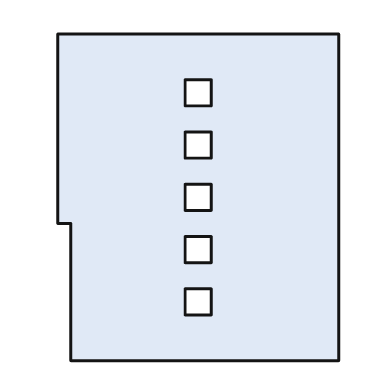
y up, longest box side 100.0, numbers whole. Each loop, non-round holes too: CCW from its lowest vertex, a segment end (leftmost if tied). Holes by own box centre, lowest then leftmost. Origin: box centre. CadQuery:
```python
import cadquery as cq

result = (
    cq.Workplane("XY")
    .moveTo(-39.0, -50.0)
    .lineTo(43.0, -50.0)
    .lineTo(43.0, 50.0)
    .lineTo(-43.0, 50.0)
    .lineTo(-43.0, -8.0)
    .lineTo(-39.0, -8.0)
    .close()
    .moveTo(-4.0, -36.0)
    .lineTo(4.0, -36.0)
    .lineTo(4.0, -28.0)
    .lineTo(-4.0, -28.0)
    .close()
    .moveTo(-4.0, -20.0)
    .lineTo(4.0, -20.0)
    .lineTo(4.0, -12.0)
    .lineTo(-4.0, -12.0)
    .close()
    .moveTo(-4.0, -4.0)
    .lineTo(4.0, -4.0)
    .lineTo(4.0, 4.0)
    .lineTo(-4.0, 4.0)
    .close()
    .moveTo(-4.0, 12.0)
    .lineTo(4.0, 12.0)
    .lineTo(4.0, 20.0)
    .lineTo(-4.0, 20.0)
    .close()
    .moveTo(-4.0, 28.0)
    .lineTo(4.0, 28.0)
    .lineTo(4.0, 36.0)
    .lineTo(-4.0, 36.0)
    .close()
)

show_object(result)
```